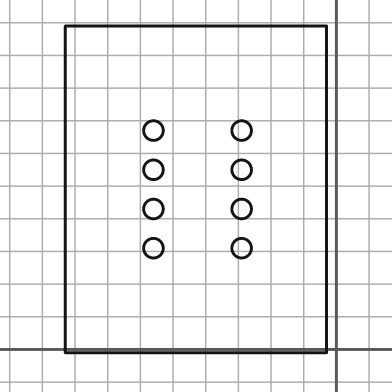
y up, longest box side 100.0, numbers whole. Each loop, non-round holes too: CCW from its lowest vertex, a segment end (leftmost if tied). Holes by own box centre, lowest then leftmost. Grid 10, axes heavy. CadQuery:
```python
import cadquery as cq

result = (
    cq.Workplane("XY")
    .moveTo(-83.0, -1.0)
    .lineTo(-3.0, -1.0)
    .lineTo(-3.0, 99.0)
    .lineTo(-83.0, 99.0)
    .close()
    .moveTo(-56.0, 31.0)
    .circle(3.0)
    .moveTo(-29.0, 31.0)
    .circle(3.0)
    .moveTo(-56.0, 43.0)
    .circle(3.0)
    .moveTo(-29.0, 43.0)
    .circle(3.0)
    .moveTo(-56.0, 55.0)
    .circle(3.0)
    .moveTo(-29.0, 55.0)
    .circle(3.0)
    .moveTo(-56.0, 67.0)
    .circle(3.0)
    .moveTo(-29.0, 67.0)
    .circle(3.0)
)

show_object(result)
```